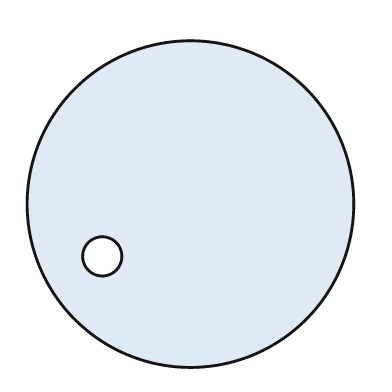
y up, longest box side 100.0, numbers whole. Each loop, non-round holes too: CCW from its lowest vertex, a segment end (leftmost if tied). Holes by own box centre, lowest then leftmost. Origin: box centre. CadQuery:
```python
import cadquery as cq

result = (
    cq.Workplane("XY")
    .moveTo(0.0, 0.0)
    .circle(50.0)
    .moveTo(-27.0, -16.0)
    .circle(6.0)
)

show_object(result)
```